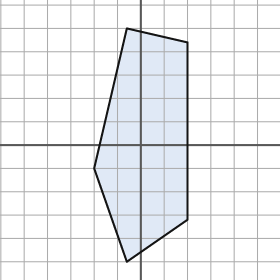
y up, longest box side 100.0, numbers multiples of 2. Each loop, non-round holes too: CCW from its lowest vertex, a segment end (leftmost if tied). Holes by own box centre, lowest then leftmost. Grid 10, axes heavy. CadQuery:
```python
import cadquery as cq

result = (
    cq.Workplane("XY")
    .moveTo(-6.0, -50.0)
    .lineTo(20.0, -32.0)
    .lineTo(20.0, 44.0)
    .lineTo(-6.0, 50.0)
    .lineTo(-20.0, -10.0)
    .close()
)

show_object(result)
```